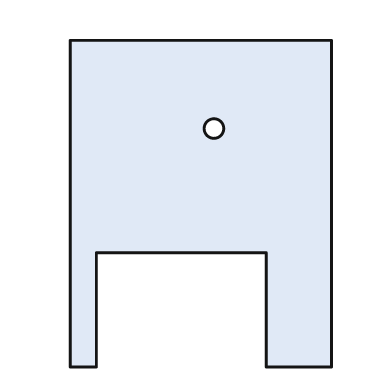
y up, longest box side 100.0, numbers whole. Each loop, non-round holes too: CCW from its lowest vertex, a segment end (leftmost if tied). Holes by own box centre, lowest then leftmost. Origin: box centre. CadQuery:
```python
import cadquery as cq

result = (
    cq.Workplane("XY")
    .moveTo(-40.0, -50.0)
    .lineTo(-32.0, -50.0)
    .lineTo(-32.0, -15.0)
    .lineTo(20.0, -15.0)
    .lineTo(20.0, -50.0)
    .lineTo(40.0, -50.0)
    .lineTo(40.0, 50.0)
    .lineTo(-40.0, 50.0)
    .close()
    .moveTo(4.0, 23.0)
    .circle(3.0)
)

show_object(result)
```